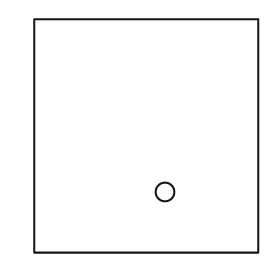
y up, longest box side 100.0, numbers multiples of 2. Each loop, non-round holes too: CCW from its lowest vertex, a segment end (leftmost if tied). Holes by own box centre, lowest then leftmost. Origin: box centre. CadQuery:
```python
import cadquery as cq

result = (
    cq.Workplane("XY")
    .moveTo(-48.0, -50.0)
    .lineTo(48.0, -50.0)
    .lineTo(48.0, 50.0)
    .lineTo(-48.0, 50.0)
    .close()
    .moveTo(8.0, -24.0)
    .circle(4.0)
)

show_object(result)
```